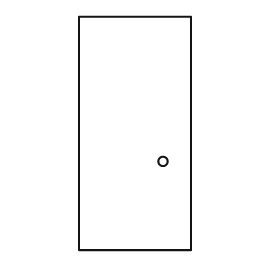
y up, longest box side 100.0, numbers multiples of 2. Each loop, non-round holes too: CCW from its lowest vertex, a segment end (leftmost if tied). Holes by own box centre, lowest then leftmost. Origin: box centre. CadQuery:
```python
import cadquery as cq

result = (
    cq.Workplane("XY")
    .moveTo(-24.0, -50.0)
    .lineTo(24.0, -50.0)
    .lineTo(24.0, 50.0)
    .lineTo(-24.0, 50.0)
    .close()
    .moveTo(12.0, -12.0)
    .circle(2.0)
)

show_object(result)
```